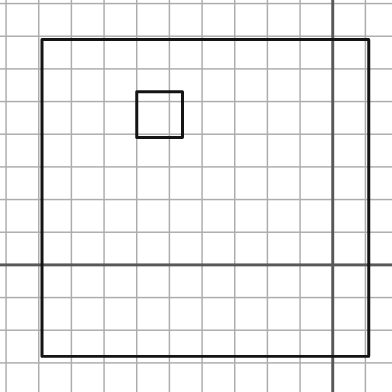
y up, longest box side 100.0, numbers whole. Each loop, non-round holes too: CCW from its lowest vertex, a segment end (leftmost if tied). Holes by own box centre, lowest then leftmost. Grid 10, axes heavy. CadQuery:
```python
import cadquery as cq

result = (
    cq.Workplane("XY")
    .moveTo(-89.0, -28.0)
    .lineTo(11.0, -28.0)
    .lineTo(11.0, 69.0)
    .lineTo(-89.0, 69.0)
    .close()
    .moveTo(-60.0, 39.0)
    .lineTo(-46.0, 39.0)
    .lineTo(-46.0, 53.0)
    .lineTo(-60.0, 53.0)
    .close()
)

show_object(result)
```